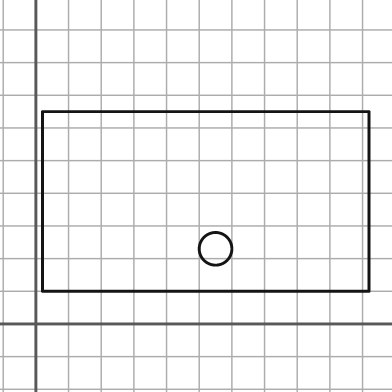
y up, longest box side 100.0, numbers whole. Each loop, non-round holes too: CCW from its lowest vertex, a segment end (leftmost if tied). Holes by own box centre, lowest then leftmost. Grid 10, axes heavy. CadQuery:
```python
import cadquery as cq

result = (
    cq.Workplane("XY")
    .moveTo(2.0, 10.0)
    .lineTo(102.0, 10.0)
    .lineTo(102.0, 65.0)
    .lineTo(2.0, 65.0)
    .close()
    .moveTo(55.0, 23.0)
    .circle(5.0)
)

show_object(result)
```